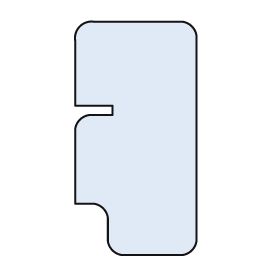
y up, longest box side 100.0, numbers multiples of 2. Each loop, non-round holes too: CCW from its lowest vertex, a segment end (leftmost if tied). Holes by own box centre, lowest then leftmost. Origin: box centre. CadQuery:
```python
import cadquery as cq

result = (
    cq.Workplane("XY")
    .moveTo(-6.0, -50.0)
    .lineTo(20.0, -50.0)
    .threePointArc((24.0, -48.0), (26.0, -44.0))
    .lineTo(26.0, 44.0)
    .threePointArc((24.0, 48.0), (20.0, 50.0))
    .lineTo(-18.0, 50.0)
    .threePointArc((-24.0, 48.0), (-26.0, 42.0))
    .lineTo(-26.0, 14.0)
    .lineTo(-10.0, 14.0)
    .lineTo(-10.0, 10.0)
    .lineTo(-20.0, 10.0)
    .threePointArc((-24.0, 8.0), (-26.0, 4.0))
    .lineTo(-26.0, -28.0)
    .lineTo(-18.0, -28.0)
    .threePointArc((-14.0, -30.0), (-12.0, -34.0))
    .lineTo(-12.0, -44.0)
    .threePointArc((-10.0, -48.0), (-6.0, -50.0))
    .close()
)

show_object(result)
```